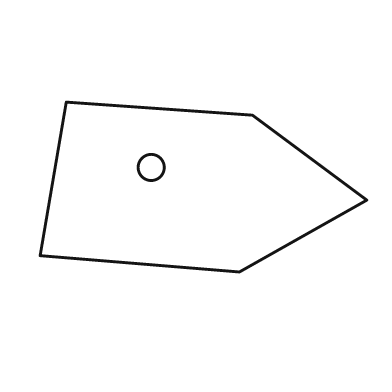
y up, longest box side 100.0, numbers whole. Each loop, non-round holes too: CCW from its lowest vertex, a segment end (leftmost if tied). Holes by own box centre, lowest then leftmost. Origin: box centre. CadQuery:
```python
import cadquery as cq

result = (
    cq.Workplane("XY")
    .moveTo(11.0, -26.0)
    .lineTo(50.0, -4.0)
    .lineTo(15.0, 22.0)
    .lineTo(-42.0, 26.0)
    .lineTo(-50.0, -21.0)
    .close()
    .moveTo(-16.0, 6.0)
    .circle(4.0)
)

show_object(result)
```